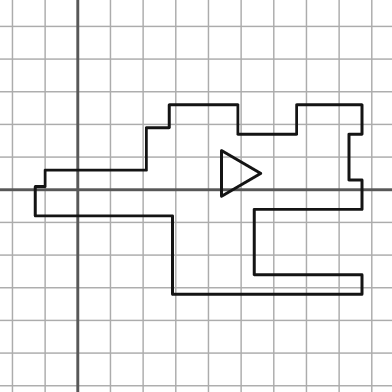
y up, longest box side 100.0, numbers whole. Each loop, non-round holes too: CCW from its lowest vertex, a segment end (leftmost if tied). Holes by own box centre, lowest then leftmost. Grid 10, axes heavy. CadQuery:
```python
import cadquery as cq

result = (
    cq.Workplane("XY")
    .moveTo(29.0, -32.0)
    .lineTo(87.0, -32.0)
    .lineTo(87.0, -26.0)
    .lineTo(54.0, -26.0)
    .lineTo(54.0, -6.0)
    .lineTo(87.0, -6.0)
    .lineTo(87.0, 3.0)
    .lineTo(83.0, 3.0)
    .lineTo(83.0, 17.0)
    .lineTo(87.0, 17.0)
    .lineTo(87.0, 26.0)
    .lineTo(67.0, 26.0)
    .lineTo(67.0, 17.0)
    .lineTo(49.0, 17.0)
    .lineTo(49.0, 26.0)
    .lineTo(28.0, 26.0)
    .lineTo(28.0, 19.0)
    .lineTo(21.0, 19.0)
    .lineTo(21.0, 6.0)
    .lineTo(-10.0, 6.0)
    .lineTo(-10.0, 1.0)
    .lineTo(-13.0, 1.0)
    .lineTo(-13.0, -8.0)
    .lineTo(29.0, -8.0)
    .close()
    .moveTo(44.0, -2.0)
    .lineTo(56.0, 5.0)
    .lineTo(44.0, 12.0)
    .close()
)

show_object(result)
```